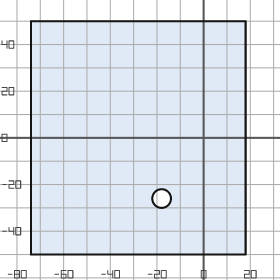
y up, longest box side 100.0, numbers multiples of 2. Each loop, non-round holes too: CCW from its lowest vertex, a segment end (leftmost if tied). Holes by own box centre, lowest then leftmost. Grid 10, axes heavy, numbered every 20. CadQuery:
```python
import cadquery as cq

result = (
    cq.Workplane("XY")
    .moveTo(-74.0, -50.0)
    .lineTo(18.0, -50.0)
    .lineTo(18.0, 50.0)
    .lineTo(-74.0, 50.0)
    .close()
    .moveTo(-18.0, -26.0)
    .circle(4.0)
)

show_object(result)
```